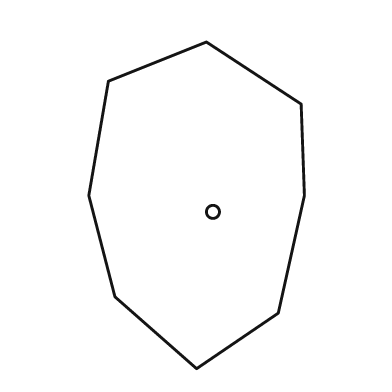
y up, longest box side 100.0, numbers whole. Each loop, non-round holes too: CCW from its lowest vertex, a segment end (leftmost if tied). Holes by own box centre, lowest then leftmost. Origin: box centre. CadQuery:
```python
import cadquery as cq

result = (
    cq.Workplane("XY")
    .moveTo(0.0, -50.0)
    .lineTo(25.0, -33.0)
    .lineTo(33.0, 3.0)
    .lineTo(32.0, 31.0)
    .lineTo(3.0, 50.0)
    .lineTo(-27.0, 38.0)
    .lineTo(-33.0, 3.0)
    .lineTo(-25.0, -28.0)
    .close()
    .moveTo(5.0, -2.0)
    .circle(2.0)
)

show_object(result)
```